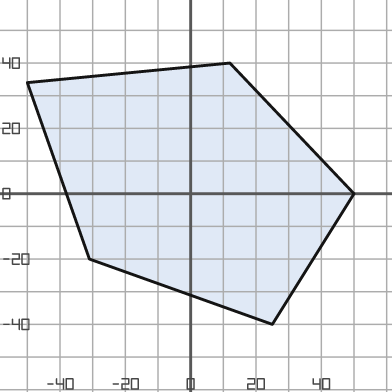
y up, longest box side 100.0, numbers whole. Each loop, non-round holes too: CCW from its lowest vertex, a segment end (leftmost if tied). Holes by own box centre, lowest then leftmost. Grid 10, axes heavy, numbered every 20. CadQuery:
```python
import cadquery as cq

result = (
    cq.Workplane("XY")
    .moveTo(25.0, -40.0)
    .lineTo(50.0, 0.0)
    .lineTo(12.0, 40.0)
    .lineTo(-50.0, 34.0)
    .lineTo(-31.0, -20.0)
    .close()
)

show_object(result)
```